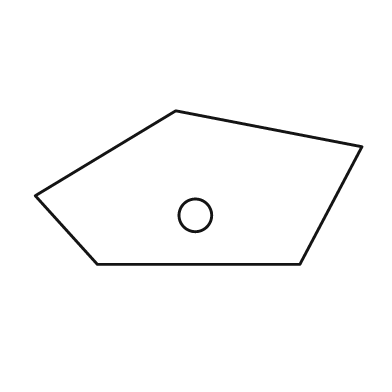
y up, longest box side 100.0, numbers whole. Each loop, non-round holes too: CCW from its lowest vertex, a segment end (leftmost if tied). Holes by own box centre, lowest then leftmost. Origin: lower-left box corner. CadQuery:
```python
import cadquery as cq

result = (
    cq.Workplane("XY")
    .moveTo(19.0, 0.0)
    .lineTo(81.0, 0.0)
    .lineTo(100.0, 36.0)
    .lineTo(43.0, 47.0)
    .lineTo(0.0, 21.0)
    .close()
    .moveTo(49.0, 15.0)
    .circle(5.0)
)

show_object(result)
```